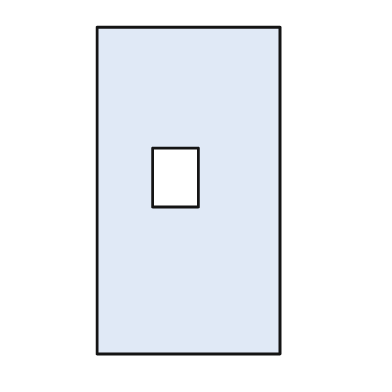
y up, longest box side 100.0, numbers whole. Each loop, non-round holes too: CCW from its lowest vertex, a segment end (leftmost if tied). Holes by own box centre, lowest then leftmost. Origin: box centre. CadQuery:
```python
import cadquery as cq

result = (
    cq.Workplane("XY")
    .moveTo(-28.0, -50.0)
    .lineTo(28.0, -50.0)
    .lineTo(28.0, 50.0)
    .lineTo(-28.0, 50.0)
    .close()
    .moveTo(-11.0, -5.0)
    .lineTo(3.0, -5.0)
    .lineTo(3.0, 13.0)
    .lineTo(-11.0, 13.0)
    .close()
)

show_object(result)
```